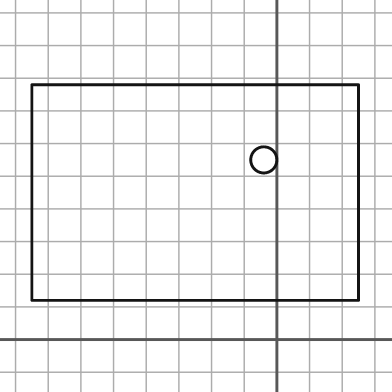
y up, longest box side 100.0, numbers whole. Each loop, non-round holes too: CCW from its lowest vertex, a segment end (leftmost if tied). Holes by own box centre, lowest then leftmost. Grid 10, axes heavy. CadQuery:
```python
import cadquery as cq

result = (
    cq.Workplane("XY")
    .moveTo(-75.0, 12.0)
    .lineTo(25.0, 12.0)
    .lineTo(25.0, 78.0)
    .lineTo(-75.0, 78.0)
    .close()
    .moveTo(-4.0, 55.0)
    .circle(4.0)
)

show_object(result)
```